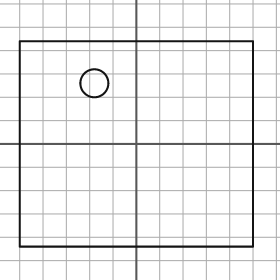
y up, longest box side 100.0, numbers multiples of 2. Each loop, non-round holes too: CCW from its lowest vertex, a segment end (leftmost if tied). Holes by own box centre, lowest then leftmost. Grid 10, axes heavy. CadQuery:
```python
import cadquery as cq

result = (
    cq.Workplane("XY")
    .moveTo(-50.0, -44.0)
    .lineTo(50.0, -44.0)
    .lineTo(50.0, 44.0)
    .lineTo(-50.0, 44.0)
    .close()
    .moveTo(-18.0, 26.0)
    .circle(6.0)
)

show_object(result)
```